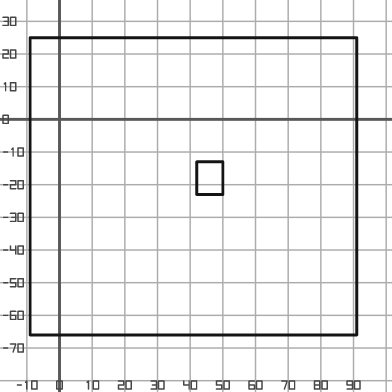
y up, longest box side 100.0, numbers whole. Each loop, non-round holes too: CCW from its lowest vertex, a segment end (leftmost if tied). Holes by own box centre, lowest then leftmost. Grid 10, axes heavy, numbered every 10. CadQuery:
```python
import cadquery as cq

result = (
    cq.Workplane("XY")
    .moveTo(-9.0, -66.0)
    .lineTo(91.0, -66.0)
    .lineTo(91.0, 25.0)
    .lineTo(-9.0, 25.0)
    .close()
    .moveTo(42.0, -23.0)
    .lineTo(50.0, -23.0)
    .lineTo(50.0, -13.0)
    .lineTo(42.0, -13.0)
    .close()
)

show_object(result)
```